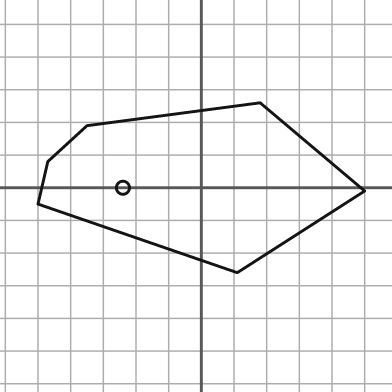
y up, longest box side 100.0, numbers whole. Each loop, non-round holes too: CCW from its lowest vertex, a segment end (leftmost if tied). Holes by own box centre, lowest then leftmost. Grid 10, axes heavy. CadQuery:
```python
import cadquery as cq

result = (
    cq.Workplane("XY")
    .moveTo(11.0, -26.0)
    .lineTo(50.0, -1.0)
    .lineTo(18.0, 26.0)
    .lineTo(-35.0, 19.0)
    .lineTo(-47.0, 8.0)
    .lineTo(-50.0, -5.0)
    .close()
    .moveTo(-24.0, 0.0)
    .circle(2.0)
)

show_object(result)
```